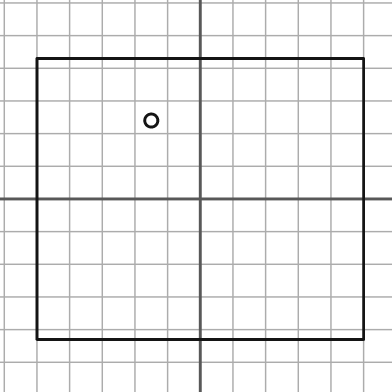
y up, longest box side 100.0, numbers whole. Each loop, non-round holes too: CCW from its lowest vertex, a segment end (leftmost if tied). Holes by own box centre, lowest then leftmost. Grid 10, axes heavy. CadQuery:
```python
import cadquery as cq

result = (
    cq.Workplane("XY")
    .moveTo(-50.0, -43.0)
    .lineTo(50.0, -43.0)
    .lineTo(50.0, 43.0)
    .lineTo(-50.0, 43.0)
    .close()
    .moveTo(-15.0, 24.0)
    .circle(2.0)
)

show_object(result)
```